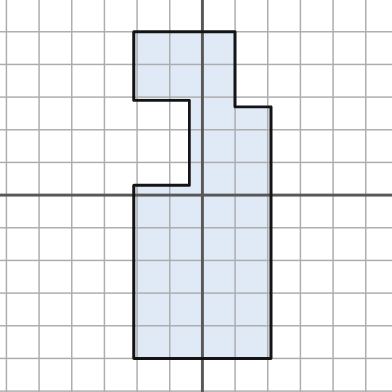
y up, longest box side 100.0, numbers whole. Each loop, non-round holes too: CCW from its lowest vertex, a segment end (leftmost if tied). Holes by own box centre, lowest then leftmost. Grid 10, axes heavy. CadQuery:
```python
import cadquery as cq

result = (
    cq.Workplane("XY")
    .moveTo(-21.0, -50.0)
    .lineTo(21.0, -50.0)
    .lineTo(21.0, 27.0)
    .lineTo(10.0, 27.0)
    .lineTo(10.0, 50.0)
    .lineTo(-21.0, 50.0)
    .lineTo(-21.0, 29.0)
    .lineTo(-4.0, 29.0)
    .lineTo(-4.0, 3.0)
    .lineTo(-21.0, 3.0)
    .close()
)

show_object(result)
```